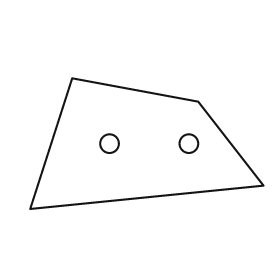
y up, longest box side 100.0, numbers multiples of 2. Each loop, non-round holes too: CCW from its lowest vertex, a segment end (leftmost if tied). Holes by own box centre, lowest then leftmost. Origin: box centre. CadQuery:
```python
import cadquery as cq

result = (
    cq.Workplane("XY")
    .moveTo(-50.0, -28.0)
    .lineTo(50.0, -18.0)
    .lineTo(22.0, 18.0)
    .lineTo(-32.0, 28.0)
    .close()
    .moveTo(-16.0, 0.0)
    .circle(4.0)
    .moveTo(18.0, 0.0)
    .circle(4.0)
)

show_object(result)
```